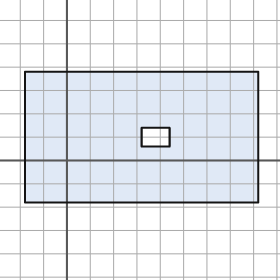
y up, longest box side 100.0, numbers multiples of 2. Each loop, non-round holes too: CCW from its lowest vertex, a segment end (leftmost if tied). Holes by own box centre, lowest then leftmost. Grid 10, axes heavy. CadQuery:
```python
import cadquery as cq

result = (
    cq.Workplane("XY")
    .moveTo(-18.0, -18.0)
    .lineTo(82.0, -18.0)
    .lineTo(82.0, 38.0)
    .lineTo(-18.0, 38.0)
    .close()
    .moveTo(32.0, 6.0)
    .lineTo(44.0, 6.0)
    .lineTo(44.0, 14.0)
    .lineTo(32.0, 14.0)
    .close()
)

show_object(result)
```